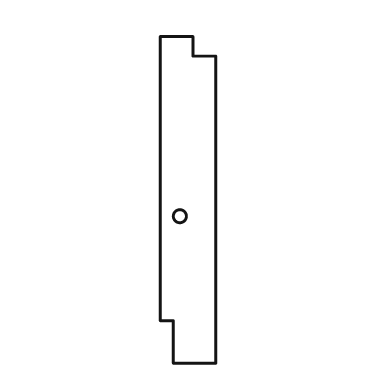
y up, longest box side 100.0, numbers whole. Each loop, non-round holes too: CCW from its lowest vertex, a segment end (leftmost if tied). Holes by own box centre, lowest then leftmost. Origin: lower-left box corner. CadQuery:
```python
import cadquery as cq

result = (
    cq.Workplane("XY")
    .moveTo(4.0, 0.0)
    .lineTo(17.0, 0.0)
    .lineTo(17.0, 94.0)
    .lineTo(10.0, 94.0)
    .lineTo(10.0, 100.0)
    .lineTo(0.0, 100.0)
    .lineTo(0.0, 13.0)
    .lineTo(4.0, 13.0)
    .close()
    .moveTo(6.0, 45.0)
    .circle(2.0)
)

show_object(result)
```